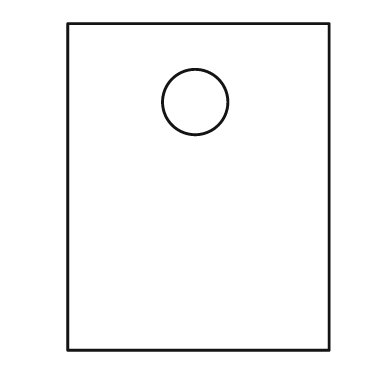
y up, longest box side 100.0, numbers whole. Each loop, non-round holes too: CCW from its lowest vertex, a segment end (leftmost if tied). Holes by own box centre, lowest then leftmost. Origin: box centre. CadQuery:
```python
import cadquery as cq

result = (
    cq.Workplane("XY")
    .moveTo(-40.0, -50.0)
    .lineTo(40.0, -50.0)
    .lineTo(40.0, 50.0)
    .lineTo(-40.0, 50.0)
    .close()
    .moveTo(-1.0, 26.0)
    .circle(10.0)
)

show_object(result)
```